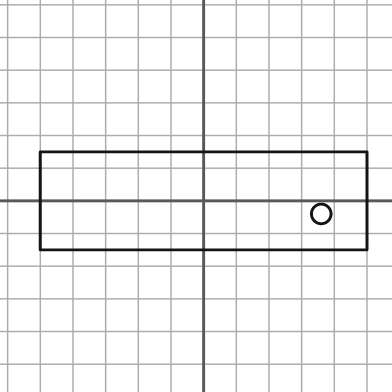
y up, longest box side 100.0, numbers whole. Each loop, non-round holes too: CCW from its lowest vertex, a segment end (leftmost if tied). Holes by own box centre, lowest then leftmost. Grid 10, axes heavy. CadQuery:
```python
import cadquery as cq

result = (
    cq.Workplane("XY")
    .moveTo(-50.0, -15.0)
    .lineTo(50.0, -15.0)
    .lineTo(50.0, 15.0)
    .lineTo(-50.0, 15.0)
    .close()
    .moveTo(36.0, -4.0)
    .circle(3.0)
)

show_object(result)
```